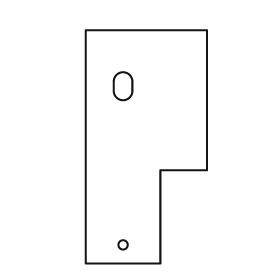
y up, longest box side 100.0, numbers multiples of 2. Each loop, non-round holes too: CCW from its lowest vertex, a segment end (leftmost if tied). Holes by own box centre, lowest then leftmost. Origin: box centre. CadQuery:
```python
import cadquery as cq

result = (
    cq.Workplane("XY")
    .moveTo(-26.0, -50.0)
    .lineTo(6.0, -50.0)
    .lineTo(6.0, -10.0)
    .lineTo(26.0, -10.0)
    .lineTo(26.0, 50.0)
    .lineTo(-26.0, 50.0)
    .close()
    .moveTo(-10.0, -42.0)
    .circle(2.0)
    .moveTo(-14.0, 24.0)
    .threePointArc((-10.0, 20.0), (-6.0, 24.0))
    .lineTo(-6.0, 28.0)
    .threePointArc((-10.0, 32.0), (-14.0, 28.0))
    .close()
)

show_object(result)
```